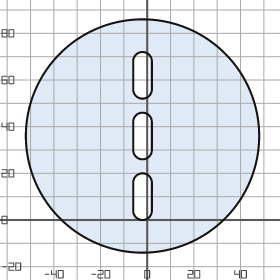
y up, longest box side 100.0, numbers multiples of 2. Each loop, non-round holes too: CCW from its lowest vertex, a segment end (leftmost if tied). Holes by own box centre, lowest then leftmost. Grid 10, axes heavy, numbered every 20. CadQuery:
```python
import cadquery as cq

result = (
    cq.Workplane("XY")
    .moveTo(-2.0, 36.0)
    .circle(50.0)
    .moveTo(-6.0, 4.0)
    .threePointArc((-2.0, 0.0), (2.0, 4.0))
    .lineTo(2.0, 16.0)
    .threePointArc((-2.0, 20.0), (-6.0, 16.0))
    .close()
    .moveTo(-6.0, 30.0)
    .threePointArc((-2.0, 26.0), (2.0, 30.0))
    .lineTo(2.0, 42.0)
    .threePointArc((-2.0, 46.0), (-6.0, 42.0))
    .close()
    .moveTo(-6.0, 56.0)
    .threePointArc((-2.0, 52.0), (2.0, 56.0))
    .lineTo(2.0, 68.0)
    .threePointArc((-2.0, 72.0), (-6.0, 68.0))
    .close()
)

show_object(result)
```